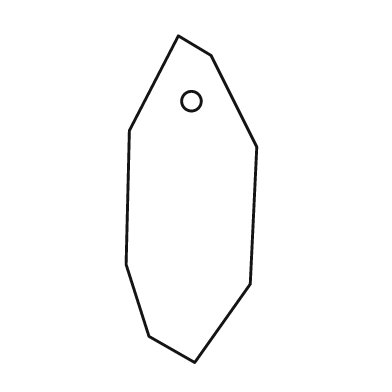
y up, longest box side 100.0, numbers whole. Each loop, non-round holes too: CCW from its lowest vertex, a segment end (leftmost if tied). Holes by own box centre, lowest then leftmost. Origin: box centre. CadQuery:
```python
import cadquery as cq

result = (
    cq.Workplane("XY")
    .moveTo(1.0, -50.0)
    .lineTo(18.0, -26.0)
    .lineTo(20.0, 16.0)
    .lineTo(6.0, 44.0)
    .lineTo(-4.0, 50.0)
    .lineTo(-19.0, 21.0)
    .lineTo(-20.0, -20.0)
    .lineTo(-13.0, -42.0)
    .close()
    .moveTo(0.0, 30.0)
    .circle(3.0)
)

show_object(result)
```